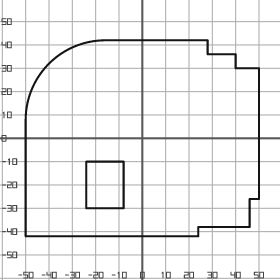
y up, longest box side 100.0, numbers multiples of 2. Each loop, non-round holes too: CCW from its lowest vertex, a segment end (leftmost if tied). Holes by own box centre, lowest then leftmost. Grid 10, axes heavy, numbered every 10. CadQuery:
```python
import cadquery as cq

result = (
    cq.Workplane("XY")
    .moveTo(-50.0, -42.0)
    .lineTo(24.0, -42.0)
    .lineTo(24.0, -38.0)
    .lineTo(46.0, -38.0)
    .lineTo(46.0, -26.0)
    .lineTo(50.0, -26.0)
    .lineTo(50.0, 30.0)
    .lineTo(40.0, 30.0)
    .lineTo(40.0, 36.0)
    .lineTo(28.0, 36.0)
    .lineTo(28.0, 42.0)
    .lineTo(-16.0, 42.0)
    .threePointArc((-40.0, 32.0), (-50.0, 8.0))
    .close()
    .moveTo(-24.0, -30.0)
    .lineTo(-8.0, -30.0)
    .lineTo(-8.0, -10.0)
    .lineTo(-24.0, -10.0)
    .close()
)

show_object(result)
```